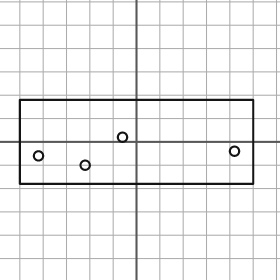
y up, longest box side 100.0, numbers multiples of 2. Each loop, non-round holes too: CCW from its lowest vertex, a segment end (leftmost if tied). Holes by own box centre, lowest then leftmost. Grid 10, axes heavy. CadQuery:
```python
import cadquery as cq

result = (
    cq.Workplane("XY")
    .moveTo(-50.0, -18.0)
    .lineTo(50.0, -18.0)
    .lineTo(50.0, 18.0)
    .lineTo(-50.0, 18.0)
    .close()
    .moveTo(-22.0, -10.0)
    .circle(2.0)
    .moveTo(-42.0, -6.0)
    .circle(2.0)
    .moveTo(42.0, -4.0)
    .circle(2.0)
    .moveTo(-6.0, 2.0)
    .circle(2.0)
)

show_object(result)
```